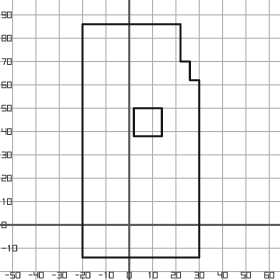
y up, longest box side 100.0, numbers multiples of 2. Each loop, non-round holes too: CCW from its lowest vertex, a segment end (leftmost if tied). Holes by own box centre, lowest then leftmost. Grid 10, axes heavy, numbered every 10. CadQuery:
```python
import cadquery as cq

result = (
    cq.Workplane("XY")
    .moveTo(-20.0, -14.0)
    .lineTo(30.0, -14.0)
    .lineTo(30.0, 62.0)
    .lineTo(26.0, 62.0)
    .lineTo(26.0, 70.0)
    .lineTo(22.0, 70.0)
    .lineTo(22.0, 86.0)
    .lineTo(-20.0, 86.0)
    .close()
    .moveTo(2.0, 38.0)
    .lineTo(14.0, 38.0)
    .lineTo(14.0, 50.0)
    .lineTo(2.0, 50.0)
    .close()
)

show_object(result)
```